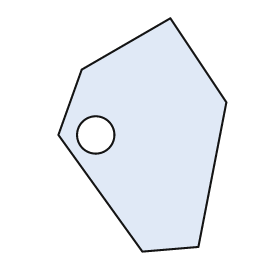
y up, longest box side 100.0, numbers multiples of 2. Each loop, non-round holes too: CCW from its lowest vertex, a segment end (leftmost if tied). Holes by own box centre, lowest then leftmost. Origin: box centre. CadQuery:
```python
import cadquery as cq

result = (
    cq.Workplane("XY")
    .moveTo(0.0, -50.0)
    .lineTo(24.0, -48.0)
    .lineTo(36.0, 14.0)
    .lineTo(12.0, 50.0)
    .lineTo(-26.0, 28.0)
    .lineTo(-36.0, 0.0)
    .close()
    .moveTo(-20.0, 0.0)
    .circle(8.0)
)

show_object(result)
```